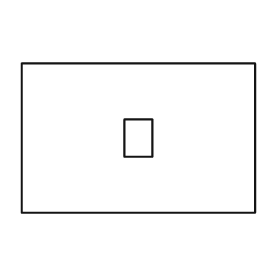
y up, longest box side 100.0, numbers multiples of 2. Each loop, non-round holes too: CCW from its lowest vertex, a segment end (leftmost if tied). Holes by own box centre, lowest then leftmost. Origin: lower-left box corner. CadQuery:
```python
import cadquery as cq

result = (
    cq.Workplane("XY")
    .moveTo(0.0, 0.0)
    .lineTo(100.0, 0.0)
    .lineTo(100.0, 64.0)
    .lineTo(0.0, 64.0)
    .close()
    .moveTo(44.0, 24.0)
    .lineTo(56.0, 24.0)
    .lineTo(56.0, 40.0)
    .lineTo(44.0, 40.0)
    .close()
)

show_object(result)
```